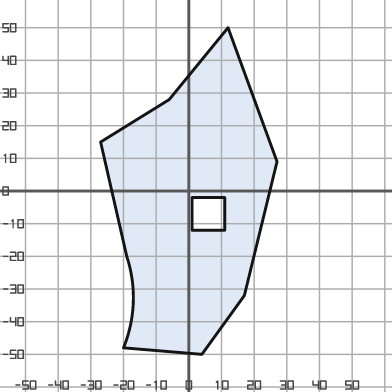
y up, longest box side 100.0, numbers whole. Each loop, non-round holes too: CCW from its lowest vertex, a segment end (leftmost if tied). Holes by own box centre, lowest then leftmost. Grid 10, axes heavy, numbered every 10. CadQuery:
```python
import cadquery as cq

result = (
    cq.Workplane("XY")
    .moveTo(4.0, -50.0)
    .lineTo(17.0, -32.0)
    .lineTo(27.0, 9.0)
    .lineTo(12.0, 50.0)
    .lineTo(-6.0, 28.0)
    .lineTo(-27.0, 15.0)
    .lineTo(-19.0, -20.0)
    .threePointArc((-17.0, -34.0), (-20.0, -48.0))
    .close()
    .moveTo(1.0, -12.0)
    .lineTo(11.0, -12.0)
    .lineTo(11.0, -2.0)
    .lineTo(1.0, -2.0)
    .close()
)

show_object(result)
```